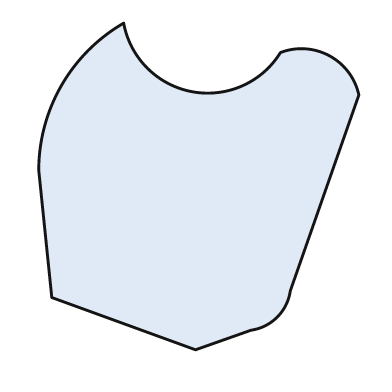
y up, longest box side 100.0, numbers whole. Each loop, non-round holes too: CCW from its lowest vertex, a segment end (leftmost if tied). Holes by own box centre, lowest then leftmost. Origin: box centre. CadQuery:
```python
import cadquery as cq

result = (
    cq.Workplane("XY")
    .moveTo(-1.0, -50.0)
    .lineTo(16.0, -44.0)
    .threePointArc((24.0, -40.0), (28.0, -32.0))
    .lineTo(49.0, 28.0)
    .threePointArc((40.0, 40.0), (25.0, 41.0))
    .threePointArc((-2.0, 29.0), (-23.0, 50.0))
    .threePointArc((-42.0, 31.0), (-49.0, 5.0))
    .lineTo(-45.0, -34.0)
    .close()
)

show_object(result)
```